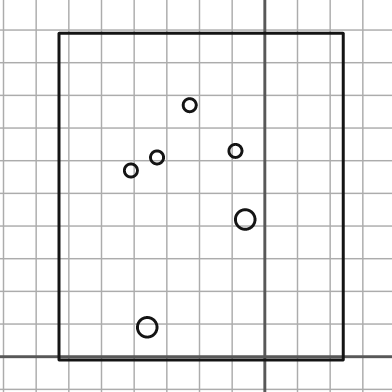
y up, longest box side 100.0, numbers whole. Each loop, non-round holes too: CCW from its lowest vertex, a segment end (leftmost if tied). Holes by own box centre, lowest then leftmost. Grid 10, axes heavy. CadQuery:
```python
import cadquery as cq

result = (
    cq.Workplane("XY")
    .moveTo(-63.0, -1.0)
    .lineTo(24.0, -1.0)
    .lineTo(24.0, 99.0)
    .lineTo(-63.0, 99.0)
    .close()
    .moveTo(-36.0, 9.0)
    .circle(3.0)
    .moveTo(-6.0, 42.0)
    .circle(3.0)
    .moveTo(-41.0, 57.0)
    .circle(2.0)
    .moveTo(-33.0, 61.0)
    .circle(2.0)
    .moveTo(-9.0, 63.0)
    .circle(2.0)
    .moveTo(-23.0, 77.0)
    .circle(2.0)
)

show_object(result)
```